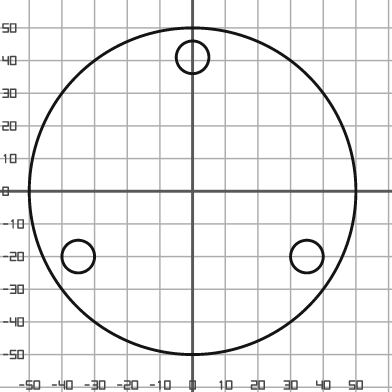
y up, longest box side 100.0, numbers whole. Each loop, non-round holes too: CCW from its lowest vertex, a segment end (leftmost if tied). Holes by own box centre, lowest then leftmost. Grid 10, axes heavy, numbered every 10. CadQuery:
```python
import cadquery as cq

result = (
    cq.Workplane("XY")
    .moveTo(0.0, 0.0)
    .circle(50.0)
    .moveTo(-35.0, -20.0)
    .circle(5.0)
    .moveTo(35.0, -20.0)
    .circle(5.0)
    .moveTo(0.0, 41.0)
    .circle(5.0)
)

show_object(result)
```